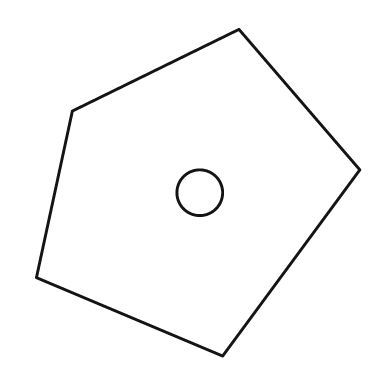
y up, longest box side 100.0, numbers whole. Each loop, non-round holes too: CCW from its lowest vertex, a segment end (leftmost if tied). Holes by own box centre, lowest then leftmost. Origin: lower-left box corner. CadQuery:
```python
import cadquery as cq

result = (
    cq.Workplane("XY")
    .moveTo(57.0, 0.0)
    .lineTo(99.0, 57.0)
    .lineTo(62.0, 100.0)
    .lineTo(11.0, 75.0)
    .lineTo(0.0, 24.0)
    .close()
    .moveTo(50.0, 50.0)
    .circle(7.0)
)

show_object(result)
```